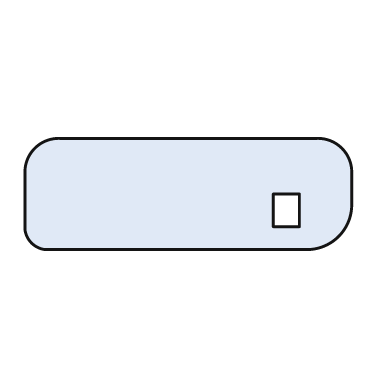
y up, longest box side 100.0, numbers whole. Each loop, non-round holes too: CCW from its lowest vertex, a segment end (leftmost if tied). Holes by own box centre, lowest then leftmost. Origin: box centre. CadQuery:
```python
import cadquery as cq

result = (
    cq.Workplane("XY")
    .moveTo(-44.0, -17.0)
    .lineTo(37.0, -17.0)
    .threePointArc((46.0, -13.0), (50.0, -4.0))
    .lineTo(50.0, 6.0)
    .threePointArc((47.0, 14.0), (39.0, 17.0))
    .lineTo(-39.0, 17.0)
    .threePointArc((-47.0, 14.0), (-50.0, 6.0))
    .lineTo(-50.0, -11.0)
    .threePointArc((-48.0, -15.0), (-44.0, -17.0))
    .close()
    .moveTo(26.0, -10.0)
    .lineTo(34.0, -10.0)
    .lineTo(34.0, 0.0)
    .lineTo(26.0, 0.0)
    .close()
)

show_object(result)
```